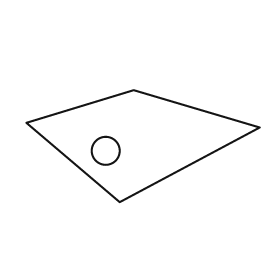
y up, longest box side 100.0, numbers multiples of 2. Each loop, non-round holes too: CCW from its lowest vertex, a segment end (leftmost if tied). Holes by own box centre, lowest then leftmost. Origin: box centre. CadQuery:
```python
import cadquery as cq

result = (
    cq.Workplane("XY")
    .moveTo(-10.0, -24.0)
    .lineTo(50.0, 8.0)
    .lineTo(-4.0, 24.0)
    .lineTo(-50.0, 10.0)
    .close()
    .moveTo(-16.0, -2.0)
    .circle(6.0)
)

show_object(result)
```